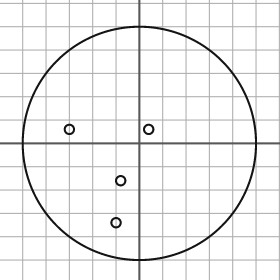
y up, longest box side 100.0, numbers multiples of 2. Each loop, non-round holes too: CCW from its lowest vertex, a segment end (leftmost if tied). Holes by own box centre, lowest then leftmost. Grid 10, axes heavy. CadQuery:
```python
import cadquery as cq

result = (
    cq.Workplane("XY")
    .moveTo(0.0, 0.0)
    .circle(50.0)
    .moveTo(-10.0, -34.0)
    .circle(2.0)
    .moveTo(-8.0, -16.0)
    .circle(2.0)
    .moveTo(-30.0, 6.0)
    .circle(2.0)
    .moveTo(4.0, 6.0)
    .circle(2.0)
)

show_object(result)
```